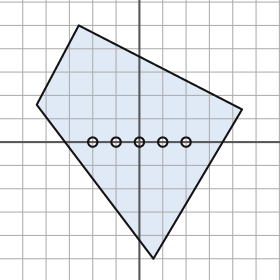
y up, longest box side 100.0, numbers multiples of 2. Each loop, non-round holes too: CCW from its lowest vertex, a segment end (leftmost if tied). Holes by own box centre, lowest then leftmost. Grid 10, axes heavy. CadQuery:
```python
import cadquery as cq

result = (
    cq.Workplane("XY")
    .moveTo(6.0, -50.0)
    .lineTo(44.0, 14.0)
    .lineTo(-26.0, 50.0)
    .lineTo(-44.0, 16.0)
    .close()
    .moveTo(-20.0, 0.0)
    .circle(2.0)
    .moveTo(-10.0, 0.0)
    .circle(2.0)
    .moveTo(0.0, 0.0)
    .circle(2.0)
    .moveTo(10.0, 0.0)
    .circle(2.0)
    .moveTo(20.0, 0.0)
    .circle(2.0)
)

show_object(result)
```